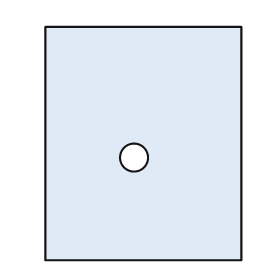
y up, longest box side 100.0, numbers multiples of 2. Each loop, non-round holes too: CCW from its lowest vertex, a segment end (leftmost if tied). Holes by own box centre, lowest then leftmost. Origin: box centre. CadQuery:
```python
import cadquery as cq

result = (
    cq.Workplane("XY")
    .moveTo(-42.0, -50.0)
    .lineTo(42.0, -50.0)
    .lineTo(42.0, 50.0)
    .lineTo(-42.0, 50.0)
    .close()
    .moveTo(-4.0, -6.0)
    .circle(6.0)
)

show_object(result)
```